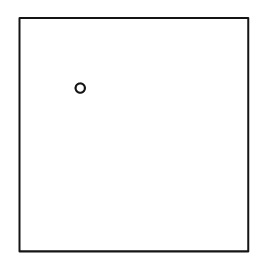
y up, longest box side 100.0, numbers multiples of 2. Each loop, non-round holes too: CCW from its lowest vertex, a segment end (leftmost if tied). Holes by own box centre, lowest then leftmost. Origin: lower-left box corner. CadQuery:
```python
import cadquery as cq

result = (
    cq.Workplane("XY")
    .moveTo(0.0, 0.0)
    .lineTo(98.0, 0.0)
    .lineTo(98.0, 100.0)
    .lineTo(0.0, 100.0)
    .close()
    .moveTo(26.0, 70.0)
    .circle(2.0)
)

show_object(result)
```